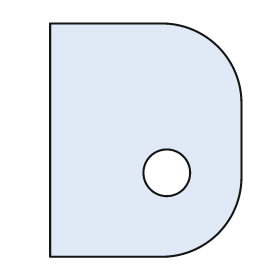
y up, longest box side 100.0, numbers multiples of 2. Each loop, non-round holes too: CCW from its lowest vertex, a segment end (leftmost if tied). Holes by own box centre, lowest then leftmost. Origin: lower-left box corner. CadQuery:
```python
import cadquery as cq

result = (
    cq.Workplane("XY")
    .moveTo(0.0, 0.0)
    .lineTo(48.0, 0.0)
    .threePointArc((72.0, 10.0), (82.0, 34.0))
    .lineTo(82.0, 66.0)
    .threePointArc((72.0, 90.0), (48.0, 100.0))
    .lineTo(0.0, 100.0)
    .close()
    .moveTo(50.0, 36.0)
    .circle(10.0)
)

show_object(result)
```